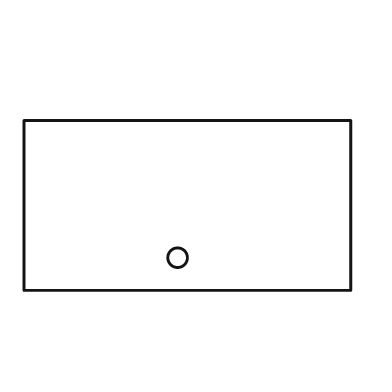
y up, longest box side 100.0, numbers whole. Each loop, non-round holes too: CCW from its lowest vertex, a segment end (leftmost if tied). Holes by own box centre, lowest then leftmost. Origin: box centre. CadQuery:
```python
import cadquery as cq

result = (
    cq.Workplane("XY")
    .moveTo(-50.0, -26.0)
    .lineTo(50.0, -26.0)
    .lineTo(50.0, 26.0)
    .lineTo(-50.0, 26.0)
    .close()
    .moveTo(-3.0, -16.0)
    .circle(3.0)
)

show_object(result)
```